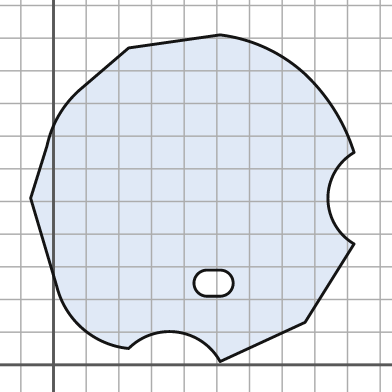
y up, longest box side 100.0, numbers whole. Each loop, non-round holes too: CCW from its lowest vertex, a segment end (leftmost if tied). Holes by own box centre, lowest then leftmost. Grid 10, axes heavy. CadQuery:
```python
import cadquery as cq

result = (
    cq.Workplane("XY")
    .moveTo(51.0, 1.0)
    .lineTo(77.0, 13.0)
    .lineTo(92.0, 37.0)
    .threePointArc((84.0, 51.0), (92.0, 65.0))
    .threePointArc((86.0, 78.0), (77.0, 89.0))
    .threePointArc((65.0, 97.0), (51.0, 101.0))
    .lineTo(23.0, 97.0)
    .lineTo(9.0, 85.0)
    .threePointArc((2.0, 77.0), (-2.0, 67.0))
    .lineTo(-7.0, 51.0)
    .lineTo(1.0, 24.0)
    .threePointArc((9.0, 11.0), (23.0, 5.0))
    .threePointArc((38.0, 10.0), (51.0, 1.0))
    .close()
    .moveTo(47.0, 21.0)
    .lineTo(51.0, 21.0)
    .threePointArc((55.0, 25.0), (51.0, 29.0))
    .lineTo(47.0, 29.0)
    .threePointArc((43.0, 25.0), (47.0, 21.0))
    .close()
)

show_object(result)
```